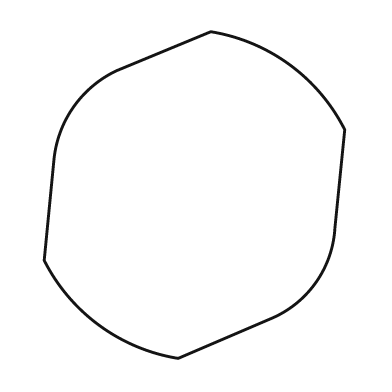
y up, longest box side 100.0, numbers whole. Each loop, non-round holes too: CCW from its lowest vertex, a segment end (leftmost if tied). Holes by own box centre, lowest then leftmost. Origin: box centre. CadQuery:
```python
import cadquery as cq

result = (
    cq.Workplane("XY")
    .moveTo(-5.0, -50.0)
    .lineTo(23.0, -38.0)
    .threePointArc((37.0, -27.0), (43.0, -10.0))
    .lineTo(46.0, 20.0)
    .threePointArc((29.0, 40.0), (5.0, 50.0))
    .lineTo(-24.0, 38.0)
    .threePointArc((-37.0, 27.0), (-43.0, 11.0))
    .lineTo(-46.0, -20.0)
    .threePointArc((-29.0, -40.0), (-5.0, -50.0))
    .close()
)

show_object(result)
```